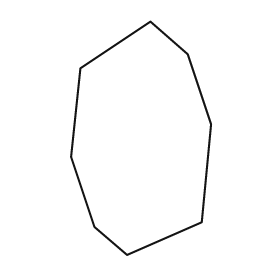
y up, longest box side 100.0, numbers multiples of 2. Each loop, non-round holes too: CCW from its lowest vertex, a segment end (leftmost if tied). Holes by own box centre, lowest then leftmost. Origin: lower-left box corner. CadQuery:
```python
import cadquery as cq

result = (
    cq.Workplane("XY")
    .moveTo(24.0, 0.0)
    .lineTo(56.0, 14.0)
    .lineTo(60.0, 56.0)
    .lineTo(50.0, 86.0)
    .lineTo(34.0, 100.0)
    .lineTo(4.0, 80.0)
    .lineTo(0.0, 42.0)
    .lineTo(10.0, 12.0)
    .close()
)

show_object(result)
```